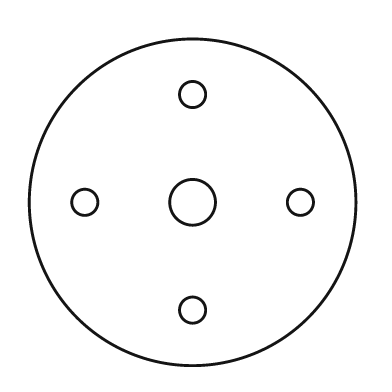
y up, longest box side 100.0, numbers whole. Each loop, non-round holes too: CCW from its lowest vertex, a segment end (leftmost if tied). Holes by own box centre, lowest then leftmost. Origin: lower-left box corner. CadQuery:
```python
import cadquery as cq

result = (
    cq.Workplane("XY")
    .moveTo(50.0, 50.0)
    .circle(50.0)
    .moveTo(50.0, 17.0)
    .circle(4.0)
    .moveTo(17.0, 50.0)
    .circle(4.0)
    .moveTo(50.0, 50.0)
    .circle(7.0)
    .moveTo(83.0, 50.0)
    .circle(4.0)
    .moveTo(50.0, 83.0)
    .circle(4.0)
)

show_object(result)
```